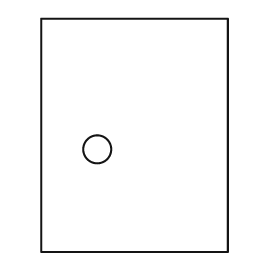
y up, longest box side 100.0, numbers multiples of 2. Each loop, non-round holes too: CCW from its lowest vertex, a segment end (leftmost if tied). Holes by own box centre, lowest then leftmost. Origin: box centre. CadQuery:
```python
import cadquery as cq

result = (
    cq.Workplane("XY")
    .moveTo(-40.0, -50.0)
    .lineTo(40.0, -50.0)
    .lineTo(40.0, 50.0)
    .lineTo(-40.0, 50.0)
    .close()
    .moveTo(-16.0, -6.0)
    .circle(6.0)
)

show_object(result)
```